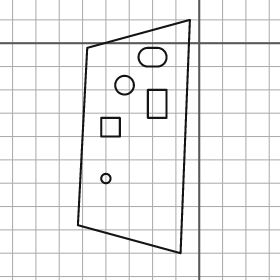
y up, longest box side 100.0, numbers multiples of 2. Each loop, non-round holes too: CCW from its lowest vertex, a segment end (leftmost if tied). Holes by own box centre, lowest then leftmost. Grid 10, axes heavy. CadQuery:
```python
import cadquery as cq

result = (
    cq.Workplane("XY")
    .moveTo(-8.0, -90.0)
    .lineTo(-4.0, 10.0)
    .lineTo(-48.0, -2.0)
    .lineTo(-52.0, -78.0)
    .close()
    .moveTo(-40.0, -58.0)
    .circle(2.0)
    .moveTo(-42.0, -40.0)
    .lineTo(-34.0, -40.0)
    .lineTo(-34.0, -32.0)
    .lineTo(-42.0, -32.0)
    .close()
    .moveTo(-22.0, -32.0)
    .lineTo(-14.0, -32.0)
    .lineTo(-14.0, -20.0)
    .lineTo(-22.0, -20.0)
    .close()
    .moveTo(-32.0, -18.0)
    .circle(4.0)
    .moveTo(-22.0, -10.0)
    .lineTo(-18.0, -10.0)
    .threePointArc((-14.0, -6.0), (-18.0, -2.0))
    .lineTo(-22.0, -2.0)
    .threePointArc((-26.0, -6.0), (-22.0, -10.0))
    .close()
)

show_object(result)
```